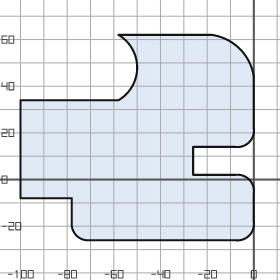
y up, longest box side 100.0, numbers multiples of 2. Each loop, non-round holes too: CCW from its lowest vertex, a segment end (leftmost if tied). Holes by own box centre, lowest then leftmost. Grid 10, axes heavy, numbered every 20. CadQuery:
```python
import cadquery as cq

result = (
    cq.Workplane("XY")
    .moveTo(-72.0, -26.0)
    .lineTo(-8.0, -26.0)
    .threePointArc((-2.0, -24.0), (0.0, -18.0))
    .lineTo(0.0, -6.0)
    .threePointArc((-2.0, 0.0), (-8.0, 2.0))
    .lineTo(-26.0, 2.0)
    .lineTo(-26.0, 14.0)
    .lineTo(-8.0, 14.0)
    .threePointArc((-2.0, 16.0), (0.0, 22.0))
    .lineTo(0.0, 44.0)
    .threePointArc((-6.0, 56.0), (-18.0, 62.0))
    .lineTo(-58.0, 62.0)
    .threePointArc((-50.0, 48.0), (-58.0, 34.0))
    .lineTo(-100.0, 34.0)
    .lineTo(-100.0, -8.0)
    .lineTo(-78.0, -8.0)
    .lineTo(-78.0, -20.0)
    .threePointArc((-76.0, -24.0), (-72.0, -26.0))
    .close()
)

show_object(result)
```